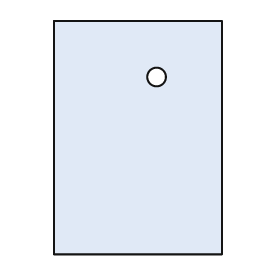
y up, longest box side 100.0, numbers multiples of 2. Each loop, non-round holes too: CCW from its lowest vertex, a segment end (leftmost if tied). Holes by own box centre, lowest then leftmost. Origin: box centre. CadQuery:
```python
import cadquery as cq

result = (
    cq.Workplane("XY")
    .moveTo(-36.0, -50.0)
    .lineTo(36.0, -50.0)
    .lineTo(36.0, 50.0)
    .lineTo(-36.0, 50.0)
    .close()
    .moveTo(8.0, 26.0)
    .circle(4.0)
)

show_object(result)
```